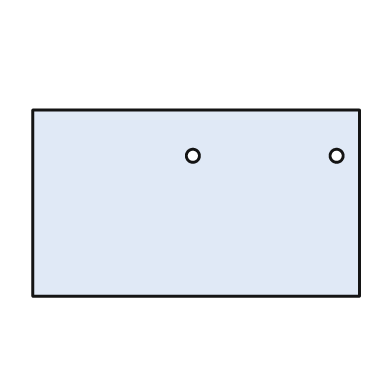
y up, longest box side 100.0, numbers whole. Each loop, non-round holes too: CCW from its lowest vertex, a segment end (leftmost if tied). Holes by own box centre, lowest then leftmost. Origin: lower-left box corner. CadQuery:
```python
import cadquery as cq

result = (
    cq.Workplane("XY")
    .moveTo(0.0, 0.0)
    .lineTo(100.0, 0.0)
    .lineTo(100.0, 57.0)
    .lineTo(0.0, 57.0)
    .close()
    .moveTo(49.0, 43.0)
    .circle(2.0)
    .moveTo(93.0, 43.0)
    .circle(2.0)
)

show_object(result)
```